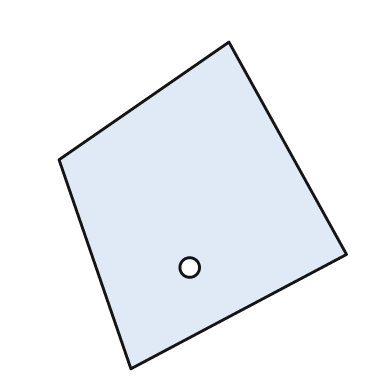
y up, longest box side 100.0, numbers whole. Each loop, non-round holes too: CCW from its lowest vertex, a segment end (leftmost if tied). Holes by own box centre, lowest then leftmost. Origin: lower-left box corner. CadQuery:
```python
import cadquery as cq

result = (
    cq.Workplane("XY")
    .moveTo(22.0, 0.0)
    .lineTo(88.0, 35.0)
    .lineTo(52.0, 100.0)
    .lineTo(0.0, 64.0)
    .close()
    .moveTo(40.0, 31.0)
    .circle(3.0)
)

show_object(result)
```